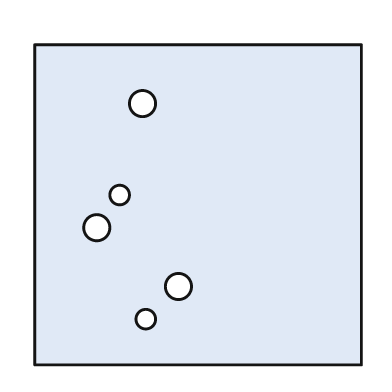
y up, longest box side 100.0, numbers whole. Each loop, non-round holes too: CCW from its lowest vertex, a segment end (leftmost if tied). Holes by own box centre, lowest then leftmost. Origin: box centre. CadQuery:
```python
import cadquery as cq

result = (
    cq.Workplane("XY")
    .moveTo(-50.0, -49.0)
    .lineTo(50.0, -49.0)
    .lineTo(50.0, 49.0)
    .lineTo(-50.0, 49.0)
    .close()
    .moveTo(-16.0, -35.0)
    .circle(3.0)
    .moveTo(-6.0, -25.0)
    .circle(4.0)
    .moveTo(-31.0, -7.0)
    .circle(4.0)
    .moveTo(-24.0, 3.0)
    .circle(3.0)
    .moveTo(-17.0, 31.0)
    .circle(4.0)
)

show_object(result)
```